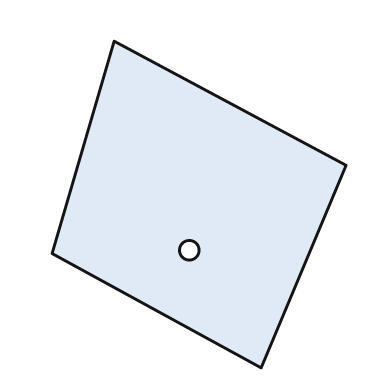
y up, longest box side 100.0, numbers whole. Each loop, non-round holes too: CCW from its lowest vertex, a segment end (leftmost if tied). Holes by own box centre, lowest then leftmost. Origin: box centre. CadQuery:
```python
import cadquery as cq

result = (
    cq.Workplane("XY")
    .moveTo(19.0, -50.0)
    .lineTo(45.0, 12.0)
    .lineTo(-26.0, 50.0)
    .lineTo(-45.0, -15.0)
    .close()
    .moveTo(-3.0, -14.0)
    .circle(3.0)
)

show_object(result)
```